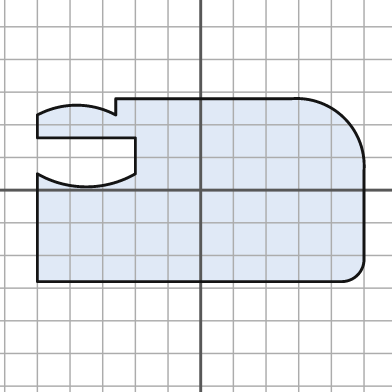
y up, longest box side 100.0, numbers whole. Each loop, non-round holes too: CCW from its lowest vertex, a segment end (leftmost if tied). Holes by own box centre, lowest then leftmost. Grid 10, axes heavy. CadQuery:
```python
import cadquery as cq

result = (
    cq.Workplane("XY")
    .moveTo(-50.0, -28.0)
    .lineTo(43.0, -28.0)
    .threePointArc((48.0, -26.0), (50.0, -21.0))
    .lineTo(50.0, 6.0)
    .threePointArc((44.0, 22.0), (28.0, 28.0))
    .lineTo(-26.0, 28.0)
    .lineTo(-26.0, 23.0)
    .threePointArc((-38.0, 26.0), (-50.0, 23.0))
    .lineTo(-50.0, 16.0)
    .lineTo(-20.0, 16.0)
    .lineTo(-20.0, 5.0)
    .threePointArc((-35.0, 1.0), (-50.0, 5.0))
    .close()
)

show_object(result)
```